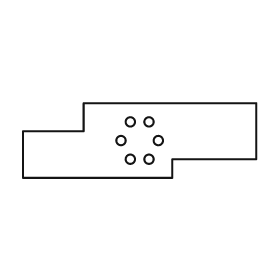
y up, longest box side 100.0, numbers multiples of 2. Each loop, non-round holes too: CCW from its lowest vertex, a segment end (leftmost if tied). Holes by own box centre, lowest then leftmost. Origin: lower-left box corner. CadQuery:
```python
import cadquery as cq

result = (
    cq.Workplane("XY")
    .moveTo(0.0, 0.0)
    .lineTo(64.0, 0.0)
    .lineTo(64.0, 8.0)
    .lineTo(100.0, 8.0)
    .lineTo(100.0, 32.0)
    .lineTo(26.0, 32.0)
    .lineTo(26.0, 20.0)
    .lineTo(0.0, 20.0)
    .close()
    .moveTo(46.0, 8.0)
    .circle(2.0)
    .moveTo(54.0, 8.0)
    .circle(2.0)
    .moveTo(42.0, 16.0)
    .circle(2.0)
    .moveTo(58.0, 16.0)
    .circle(2.0)
    .moveTo(46.0, 24.0)
    .circle(2.0)
    .moveTo(54.0, 24.0)
    .circle(2.0)
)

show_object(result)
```